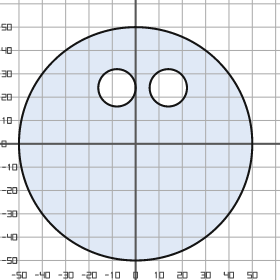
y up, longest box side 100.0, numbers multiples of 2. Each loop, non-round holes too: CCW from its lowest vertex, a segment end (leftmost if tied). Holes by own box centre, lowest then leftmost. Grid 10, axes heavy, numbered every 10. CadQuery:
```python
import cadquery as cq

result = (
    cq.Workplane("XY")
    .moveTo(0.0, 0.0)
    .circle(50.0)
    .moveTo(-8.0, 24.0)
    .circle(8.0)
    .moveTo(14.0, 24.0)
    .circle(8.0)
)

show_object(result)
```